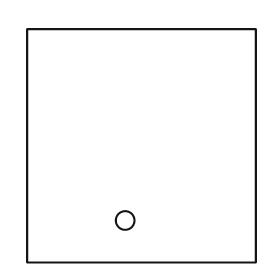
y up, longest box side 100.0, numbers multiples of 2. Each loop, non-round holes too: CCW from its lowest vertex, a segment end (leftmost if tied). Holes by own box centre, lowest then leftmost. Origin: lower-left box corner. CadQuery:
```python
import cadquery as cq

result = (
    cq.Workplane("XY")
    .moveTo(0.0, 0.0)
    .lineTo(98.0, 0.0)
    .lineTo(98.0, 100.0)
    .lineTo(0.0, 100.0)
    .close()
    .moveTo(42.0, 18.0)
    .circle(4.0)
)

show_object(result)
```